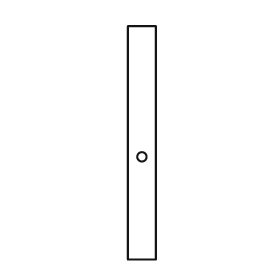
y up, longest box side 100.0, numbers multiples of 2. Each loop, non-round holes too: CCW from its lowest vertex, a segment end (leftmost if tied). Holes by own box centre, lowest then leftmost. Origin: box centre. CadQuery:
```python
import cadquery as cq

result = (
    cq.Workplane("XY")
    .moveTo(-6.0, -50.0)
    .lineTo(6.0, -50.0)
    .lineTo(6.0, 50.0)
    .lineTo(-6.0, 50.0)
    .close()
    .moveTo(0.0, -6.0)
    .circle(2.0)
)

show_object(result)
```